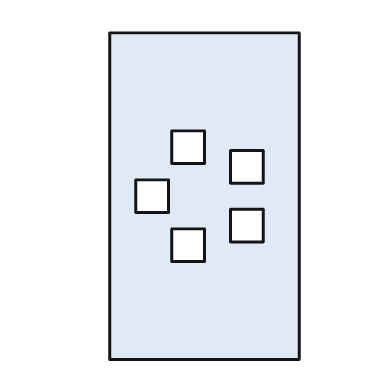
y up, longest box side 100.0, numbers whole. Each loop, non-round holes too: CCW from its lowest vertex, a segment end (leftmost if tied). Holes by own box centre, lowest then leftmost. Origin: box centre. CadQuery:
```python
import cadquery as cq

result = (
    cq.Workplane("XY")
    .moveTo(-29.0, -50.0)
    .lineTo(29.0, -50.0)
    .lineTo(29.0, 50.0)
    .lineTo(-29.0, 50.0)
    .close()
    .moveTo(-10.0, -20.0)
    .lineTo(0.0, -20.0)
    .lineTo(0.0, -10.0)
    .lineTo(-10.0, -10.0)
    .close()
    .moveTo(8.0, -14.0)
    .lineTo(18.0, -14.0)
    .lineTo(18.0, -4.0)
    .lineTo(8.0, -4.0)
    .close()
    .moveTo(-21.0, -5.0)
    .lineTo(-11.0, -5.0)
    .lineTo(-11.0, 5.0)
    .lineTo(-21.0, 5.0)
    .close()
    .moveTo(8.0, 4.0)
    .lineTo(18.0, 4.0)
    .lineTo(18.0, 14.0)
    .lineTo(8.0, 14.0)
    .close()
    .moveTo(-10.0, 10.0)
    .lineTo(0.0, 10.0)
    .lineTo(0.0, 20.0)
    .lineTo(-10.0, 20.0)
    .close()
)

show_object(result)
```